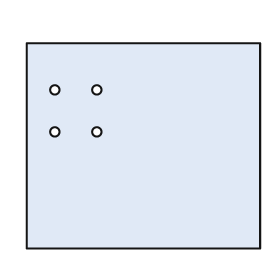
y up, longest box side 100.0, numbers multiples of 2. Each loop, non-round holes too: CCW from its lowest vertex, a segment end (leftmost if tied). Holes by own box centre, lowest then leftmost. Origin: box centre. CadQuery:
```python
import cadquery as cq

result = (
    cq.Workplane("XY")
    .moveTo(-50.0, -44.0)
    .lineTo(50.0, -44.0)
    .lineTo(50.0, 44.0)
    .lineTo(-50.0, 44.0)
    .close()
    .moveTo(-38.0, 6.0)
    .circle(2.0)
    .moveTo(-20.0, 6.0)
    .circle(2.0)
    .moveTo(-38.0, 24.0)
    .circle(2.0)
    .moveTo(-20.0, 24.0)
    .circle(2.0)
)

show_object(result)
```